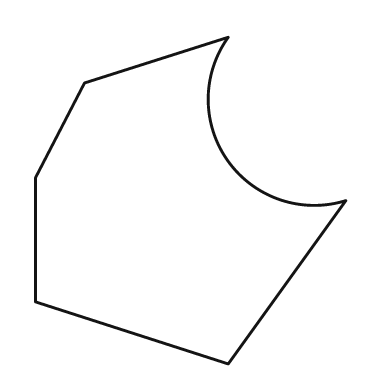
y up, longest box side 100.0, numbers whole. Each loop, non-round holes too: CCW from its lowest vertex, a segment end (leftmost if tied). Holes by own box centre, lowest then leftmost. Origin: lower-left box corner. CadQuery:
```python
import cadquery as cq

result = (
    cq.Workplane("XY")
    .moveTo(59.0, 0.0)
    .lineTo(95.0, 50.0)
    .threePointArc((59.0, 62.0), (59.0, 100.0))
    .lineTo(15.0, 86.0)
    .lineTo(0.0, 57.0)
    .lineTo(0.0, 19.0)
    .close()
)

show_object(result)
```